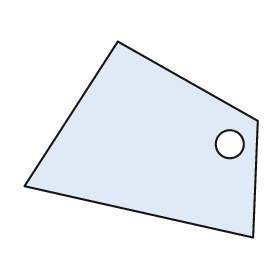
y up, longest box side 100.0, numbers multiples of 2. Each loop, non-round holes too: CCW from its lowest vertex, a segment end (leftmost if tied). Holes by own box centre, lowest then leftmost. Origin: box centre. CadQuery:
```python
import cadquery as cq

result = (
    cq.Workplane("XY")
    .moveTo(48.0, -42.0)
    .lineTo(50.0, 8.0)
    .lineTo(-10.0, 42.0)
    .lineTo(-50.0, -20.0)
    .close()
    .moveTo(38.0, -2.0)
    .circle(6.0)
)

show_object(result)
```